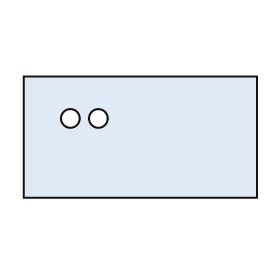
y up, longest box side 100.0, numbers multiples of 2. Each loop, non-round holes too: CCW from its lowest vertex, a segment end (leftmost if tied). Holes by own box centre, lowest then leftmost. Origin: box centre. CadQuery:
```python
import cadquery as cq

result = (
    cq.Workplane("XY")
    .moveTo(-50.0, -26.0)
    .lineTo(50.0, -26.0)
    .lineTo(50.0, 26.0)
    .lineTo(-50.0, 26.0)
    .close()
    .moveTo(-30.0, 8.0)
    .circle(4.0)
    .moveTo(-18.0, 8.0)
    .circle(4.0)
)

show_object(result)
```